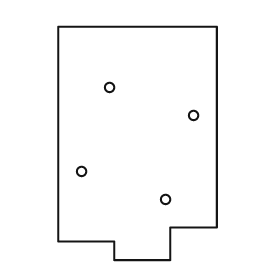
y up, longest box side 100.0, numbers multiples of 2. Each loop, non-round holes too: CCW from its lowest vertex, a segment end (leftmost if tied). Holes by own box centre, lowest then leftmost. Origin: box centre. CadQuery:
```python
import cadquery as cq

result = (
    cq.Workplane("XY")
    .moveTo(-10.0, -50.0)
    .lineTo(14.0, -50.0)
    .lineTo(14.0, -36.0)
    .lineTo(34.0, -36.0)
    .lineTo(34.0, 50.0)
    .lineTo(-34.0, 50.0)
    .lineTo(-34.0, -42.0)
    .lineTo(-10.0, -42.0)
    .close()
    .moveTo(12.0, -24.0)
    .circle(2.0)
    .moveTo(-24.0, -12.0)
    .circle(2.0)
    .moveTo(24.0, 12.0)
    .circle(2.0)
    .moveTo(-12.0, 24.0)
    .circle(2.0)
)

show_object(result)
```